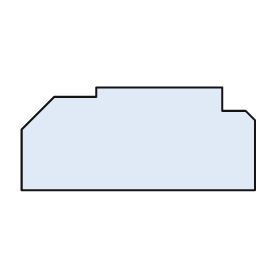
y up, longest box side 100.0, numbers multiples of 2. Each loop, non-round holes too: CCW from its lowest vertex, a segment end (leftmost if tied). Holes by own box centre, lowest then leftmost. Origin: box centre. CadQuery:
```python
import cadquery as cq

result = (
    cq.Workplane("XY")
    .moveTo(-50.0, -22.0)
    .lineTo(50.0, -22.0)
    .lineTo(50.0, 8.0)
    .lineTo(46.0, 12.0)
    .lineTo(36.0, 12.0)
    .lineTo(36.0, 22.0)
    .lineTo(-18.0, 22.0)
    .lineTo(-18.0, 18.0)
    .lineTo(-36.0, 18.0)
    .lineTo(-50.0, 4.0)
    .close()
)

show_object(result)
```